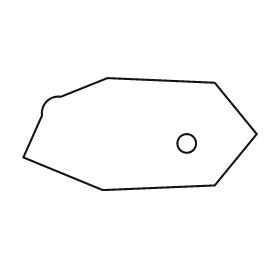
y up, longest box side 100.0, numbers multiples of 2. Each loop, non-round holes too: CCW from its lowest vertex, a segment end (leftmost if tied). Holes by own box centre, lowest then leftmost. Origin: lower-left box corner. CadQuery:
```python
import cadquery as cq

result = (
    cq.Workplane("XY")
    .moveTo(34.0, 0.0)
    .lineTo(82.0, 2.0)
    .lineTo(100.0, 24.0)
    .lineTo(82.0, 46.0)
    .lineTo(36.0, 48.0)
    .lineTo(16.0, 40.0)
    .threePointArc((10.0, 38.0), (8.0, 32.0))
    .lineTo(0.0, 14.0)
    .close()
    .moveTo(70.0, 20.0)
    .circle(4.0)
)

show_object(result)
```